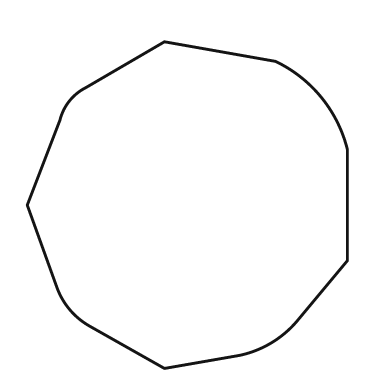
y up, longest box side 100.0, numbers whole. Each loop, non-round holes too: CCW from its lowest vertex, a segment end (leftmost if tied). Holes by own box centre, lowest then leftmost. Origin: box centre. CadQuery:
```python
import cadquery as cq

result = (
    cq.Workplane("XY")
    .moveTo(-7.0, -50.0)
    .lineTo(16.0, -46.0)
    .threePointArc((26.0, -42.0), (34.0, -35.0))
    .lineTo(49.0, -17.0)
    .lineTo(49.0, 17.0)
    .threePointArc((41.0, 33.0), (27.0, 44.0))
    .lineTo(-7.0, 50.0)
    .lineTo(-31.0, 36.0)
    .threePointArc((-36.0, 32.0), (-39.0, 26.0))
    .lineTo(-49.0, 0.0)
    .lineTo(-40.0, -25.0)
    .threePointArc((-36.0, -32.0), (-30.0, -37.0))
    .close()
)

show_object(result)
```